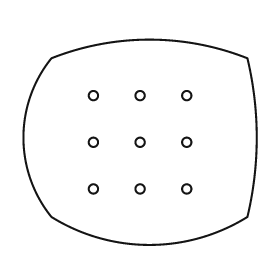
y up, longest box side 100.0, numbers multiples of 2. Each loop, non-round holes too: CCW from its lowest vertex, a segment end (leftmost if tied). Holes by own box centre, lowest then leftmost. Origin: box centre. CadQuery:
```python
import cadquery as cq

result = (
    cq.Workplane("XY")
    .moveTo(-38.0, -32.0)
    .threePointArc((4.0, -44.0), (46.0, -32.0))
    .threePointArc((50.0, 2.0), (46.0, 36.0))
    .threePointArc((4.0, 44.0), (-38.0, 36.0))
    .threePointArc((-50.0, 2.0), (-38.0, -32.0))
    .close()
    .moveTo(-20.0, -20.0)
    .circle(2.0)
    .moveTo(0.0, -20.0)
    .circle(2.0)
    .moveTo(20.0, -20.0)
    .circle(2.0)
    .moveTo(-20.0, 0.0)
    .circle(2.0)
    .moveTo(0.0, 0.0)
    .circle(2.0)
    .moveTo(20.0, 0.0)
    .circle(2.0)
    .moveTo(-20.0, 20.0)
    .circle(2.0)
    .moveTo(0.0, 20.0)
    .circle(2.0)
    .moveTo(20.0, 20.0)
    .circle(2.0)
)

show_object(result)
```